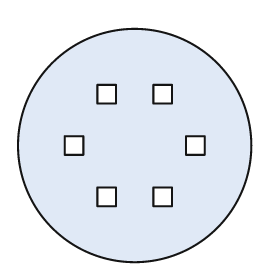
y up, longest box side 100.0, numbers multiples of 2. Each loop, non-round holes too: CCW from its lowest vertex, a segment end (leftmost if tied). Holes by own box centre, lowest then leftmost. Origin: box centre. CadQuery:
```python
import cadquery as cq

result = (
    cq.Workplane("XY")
    .moveTo(0.0, 0.0)
    .circle(50.0)
    .moveTo(-16.0, -26.0)
    .lineTo(-8.0, -26.0)
    .lineTo(-8.0, -18.0)
    .lineTo(-16.0, -18.0)
    .close()
    .moveTo(8.0, -26.0)
    .lineTo(16.0, -26.0)
    .lineTo(16.0, -18.0)
    .lineTo(8.0, -18.0)
    .close()
    .moveTo(-30.0, -4.0)
    .lineTo(-22.0, -4.0)
    .lineTo(-22.0, 4.0)
    .lineTo(-30.0, 4.0)
    .close()
    .moveTo(22.0, -4.0)
    .lineTo(30.0, -4.0)
    .lineTo(30.0, 4.0)
    .lineTo(22.0, 4.0)
    .close()
    .moveTo(-16.0, 18.0)
    .lineTo(-8.0, 18.0)
    .lineTo(-8.0, 26.0)
    .lineTo(-16.0, 26.0)
    .close()
    .moveTo(8.0, 18.0)
    .lineTo(16.0, 18.0)
    .lineTo(16.0, 26.0)
    .lineTo(8.0, 26.0)
    .close()
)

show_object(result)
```